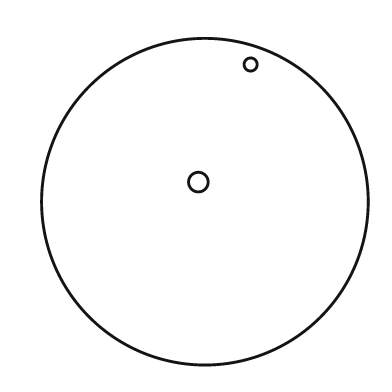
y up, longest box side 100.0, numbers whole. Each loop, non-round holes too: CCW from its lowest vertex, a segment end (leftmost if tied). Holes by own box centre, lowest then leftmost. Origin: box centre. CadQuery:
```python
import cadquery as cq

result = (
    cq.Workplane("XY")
    .moveTo(0.0, 0.0)
    .circle(50.0)
    .moveTo(-2.0, 6.0)
    .circle(3.0)
    .moveTo(14.0, 42.0)
    .circle(2.0)
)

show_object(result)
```